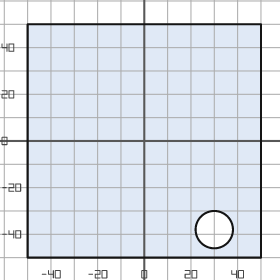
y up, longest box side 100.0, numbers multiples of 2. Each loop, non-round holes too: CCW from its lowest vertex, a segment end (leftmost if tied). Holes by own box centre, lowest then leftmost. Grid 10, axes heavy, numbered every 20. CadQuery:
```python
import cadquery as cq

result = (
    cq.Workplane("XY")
    .moveTo(-50.0, -50.0)
    .lineTo(50.0, -50.0)
    .lineTo(50.0, 50.0)
    .lineTo(-50.0, 50.0)
    .close()
    .moveTo(30.0, -38.0)
    .circle(8.0)
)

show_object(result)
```